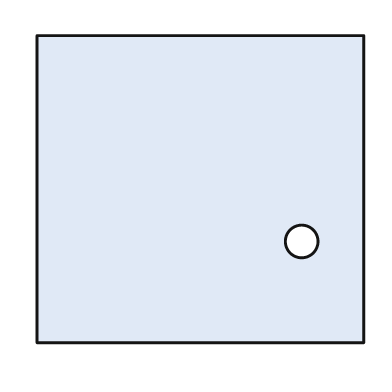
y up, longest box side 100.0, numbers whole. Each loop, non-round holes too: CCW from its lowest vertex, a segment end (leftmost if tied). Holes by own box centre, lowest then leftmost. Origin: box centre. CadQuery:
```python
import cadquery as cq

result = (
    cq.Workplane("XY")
    .moveTo(-50.0, -47.0)
    .lineTo(50.0, -47.0)
    .lineTo(50.0, 47.0)
    .lineTo(-50.0, 47.0)
    .close()
    .moveTo(31.0, -16.0)
    .circle(5.0)
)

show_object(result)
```